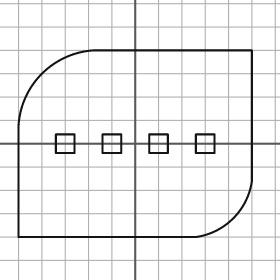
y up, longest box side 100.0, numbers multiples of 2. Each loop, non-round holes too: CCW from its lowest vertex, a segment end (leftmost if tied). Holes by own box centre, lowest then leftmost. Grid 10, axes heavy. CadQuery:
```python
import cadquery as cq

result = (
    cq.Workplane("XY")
    .moveTo(-50.0, -40.0)
    .lineTo(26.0, -40.0)
    .threePointArc((42.0, -32.0), (50.0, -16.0))
    .lineTo(50.0, 40.0)
    .lineTo(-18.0, 40.0)
    .threePointArc((-40.0, 30.0), (-50.0, 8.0))
    .close()
    .moveTo(-34.0, -4.0)
    .lineTo(-26.0, -4.0)
    .lineTo(-26.0, 4.0)
    .lineTo(-34.0, 4.0)
    .close()
    .moveTo(-14.0, -4.0)
    .lineTo(-6.0, -4.0)
    .lineTo(-6.0, 4.0)
    .lineTo(-14.0, 4.0)
    .close()
    .moveTo(6.0, -4.0)
    .lineTo(14.0, -4.0)
    .lineTo(14.0, 4.0)
    .lineTo(6.0, 4.0)
    .close()
    .moveTo(26.0, -4.0)
    .lineTo(34.0, -4.0)
    .lineTo(34.0, 4.0)
    .lineTo(26.0, 4.0)
    .close()
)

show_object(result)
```